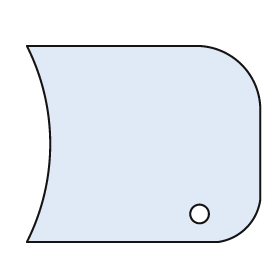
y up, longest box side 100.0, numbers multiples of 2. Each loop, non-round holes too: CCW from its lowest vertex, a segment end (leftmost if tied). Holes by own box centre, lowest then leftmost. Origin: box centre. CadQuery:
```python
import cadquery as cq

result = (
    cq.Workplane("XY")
    .moveTo(-50.0, -42.0)
    .lineTo(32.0, -42.0)
    .threePointArc((44.0, -36.0), (50.0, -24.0))
    .lineTo(50.0, 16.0)
    .threePointArc((42.0, 34.0), (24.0, 42.0))
    .lineTo(-50.0, 42.0)
    .threePointArc((-40.0, 0.0), (-50.0, -42.0))
    .close()
    .moveTo(24.0, -30.0)
    .circle(4.0)
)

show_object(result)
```